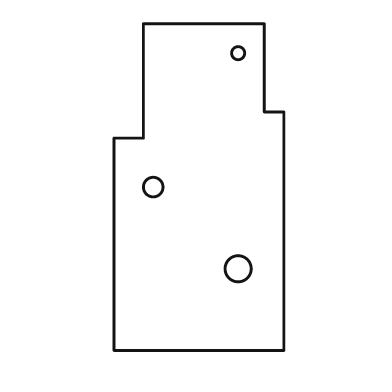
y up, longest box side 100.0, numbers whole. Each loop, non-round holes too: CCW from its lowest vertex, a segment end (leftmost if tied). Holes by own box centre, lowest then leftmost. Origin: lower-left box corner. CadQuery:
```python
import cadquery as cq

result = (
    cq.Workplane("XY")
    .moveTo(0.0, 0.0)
    .lineTo(52.0, 0.0)
    .lineTo(52.0, 73.0)
    .lineTo(46.0, 73.0)
    .lineTo(46.0, 100.0)
    .lineTo(9.0, 100.0)
    .lineTo(9.0, 65.0)
    .lineTo(0.0, 65.0)
    .close()
    .moveTo(38.0, 25.0)
    .circle(4.0)
    .moveTo(12.0, 50.0)
    .circle(3.0)
    .moveTo(38.0, 91.0)
    .circle(2.0)
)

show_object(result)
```